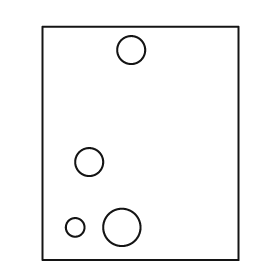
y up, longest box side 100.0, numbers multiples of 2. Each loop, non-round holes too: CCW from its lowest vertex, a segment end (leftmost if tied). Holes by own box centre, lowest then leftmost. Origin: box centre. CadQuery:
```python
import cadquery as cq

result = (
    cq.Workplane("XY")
    .moveTo(-42.0, -50.0)
    .lineTo(42.0, -50.0)
    .lineTo(42.0, 50.0)
    .lineTo(-42.0, 50.0)
    .close()
    .moveTo(-28.0, -36.0)
    .circle(4.0)
    .moveTo(-8.0, -36.0)
    .circle(8.0)
    .moveTo(-22.0, -8.0)
    .circle(6.0)
    .moveTo(-4.0, 40.0)
    .circle(6.0)
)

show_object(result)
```